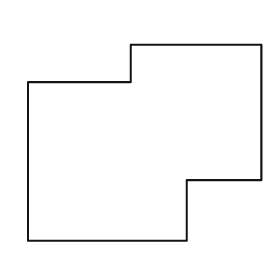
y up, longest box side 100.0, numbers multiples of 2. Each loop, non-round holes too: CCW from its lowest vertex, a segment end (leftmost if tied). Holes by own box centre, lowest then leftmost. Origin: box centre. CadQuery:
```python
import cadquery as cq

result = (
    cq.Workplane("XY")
    .moveTo(-50.0, -42.0)
    .lineTo(18.0, -42.0)
    .lineTo(18.0, -16.0)
    .lineTo(50.0, -16.0)
    .lineTo(50.0, 42.0)
    .lineTo(-6.0, 42.0)
    .lineTo(-6.0, 26.0)
    .lineTo(-50.0, 26.0)
    .close()
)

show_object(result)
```